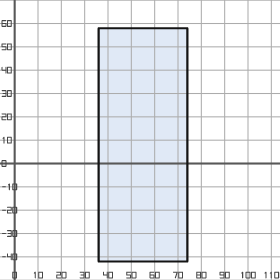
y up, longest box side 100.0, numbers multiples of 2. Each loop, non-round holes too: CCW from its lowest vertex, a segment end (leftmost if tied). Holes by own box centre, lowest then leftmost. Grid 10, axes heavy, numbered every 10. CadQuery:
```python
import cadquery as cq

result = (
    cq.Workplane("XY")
    .moveTo(36.0, -42.0)
    .lineTo(74.0, -42.0)
    .lineTo(74.0, 58.0)
    .lineTo(36.0, 58.0)
    .close()
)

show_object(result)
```